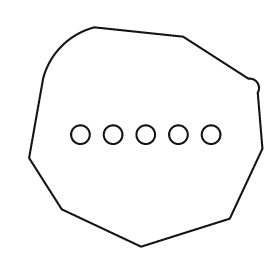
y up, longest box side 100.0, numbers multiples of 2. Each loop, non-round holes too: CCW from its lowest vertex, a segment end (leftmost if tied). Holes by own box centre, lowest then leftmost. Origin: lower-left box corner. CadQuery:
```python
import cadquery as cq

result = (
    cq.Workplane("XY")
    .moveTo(48.0, 0.0)
    .lineTo(86.0, 12.0)
    .lineTo(100.0, 42.0)
    .lineTo(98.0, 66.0)
    .threePointArc((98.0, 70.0), (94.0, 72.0))
    .lineTo(66.0, 90.0)
    .lineTo(28.0, 94.0)
    .threePointArc((14.0, 86.0), (6.0, 72.0))
    .lineTo(0.0, 38.0)
    .lineTo(14.0, 16.0)
    .close()
    .moveTo(22.0, 48.0)
    .circle(4.0)
    .moveTo(36.0, 48.0)
    .circle(4.0)
    .moveTo(50.0, 48.0)
    .circle(4.0)
    .moveTo(64.0, 48.0)
    .circle(4.0)
    .moveTo(78.0, 48.0)
    .circle(4.0)
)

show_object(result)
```